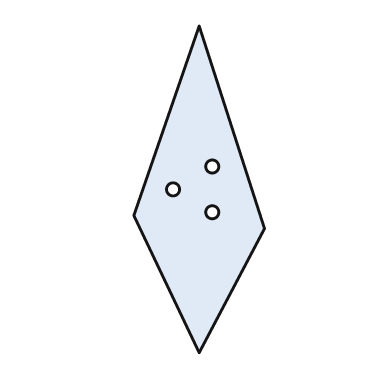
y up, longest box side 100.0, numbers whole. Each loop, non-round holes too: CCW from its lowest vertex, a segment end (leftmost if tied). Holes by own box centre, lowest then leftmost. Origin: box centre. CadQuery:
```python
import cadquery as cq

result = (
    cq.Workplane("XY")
    .moveTo(0.0, -50.0)
    .lineTo(20.0, -12.0)
    .lineTo(0.0, 50.0)
    .lineTo(-20.0, -8.0)
    .close()
    .moveTo(4.0, -7.0)
    .circle(2.0)
    .moveTo(-8.0, 0.0)
    .circle(2.0)
    .moveTo(4.0, 7.0)
    .circle(2.0)
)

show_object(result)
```